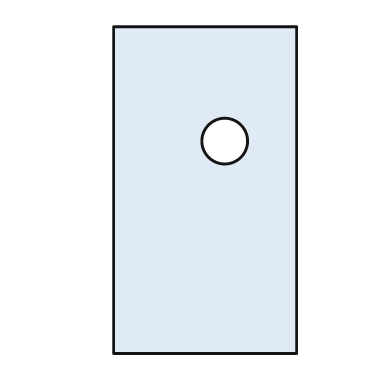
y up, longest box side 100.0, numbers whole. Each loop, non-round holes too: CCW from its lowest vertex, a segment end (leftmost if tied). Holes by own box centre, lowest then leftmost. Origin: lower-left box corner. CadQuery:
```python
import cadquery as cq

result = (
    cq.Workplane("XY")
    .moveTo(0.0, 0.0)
    .lineTo(56.0, 0.0)
    .lineTo(56.0, 100.0)
    .lineTo(0.0, 100.0)
    .close()
    .moveTo(34.0, 65.0)
    .circle(7.0)
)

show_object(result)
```